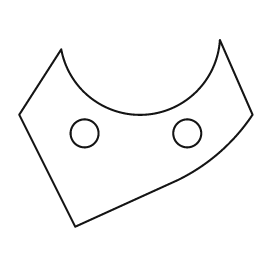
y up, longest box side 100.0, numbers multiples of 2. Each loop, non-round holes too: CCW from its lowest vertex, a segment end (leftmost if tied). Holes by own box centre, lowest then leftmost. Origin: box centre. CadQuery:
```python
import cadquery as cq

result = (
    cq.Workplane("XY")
    .moveTo(-26.0, -40.0)
    .lineTo(18.0, -20.0)
    .threePointArc((36.0, -8.0), (50.0, 8.0))
    .lineTo(36.0, 40.0)
    .threePointArc((4.0, 8.0), (-32.0, 36.0))
    .lineTo(-50.0, 8.0)
    .close()
    .moveTo(-22.0, 0.0)
    .circle(6.0)
    .moveTo(22.0, 0.0)
    .circle(6.0)
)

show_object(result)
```